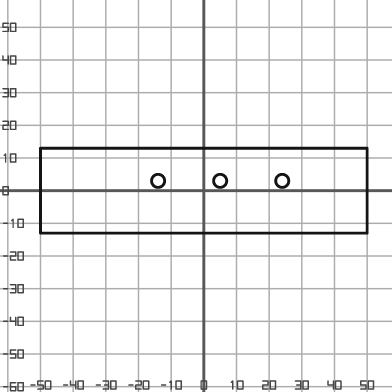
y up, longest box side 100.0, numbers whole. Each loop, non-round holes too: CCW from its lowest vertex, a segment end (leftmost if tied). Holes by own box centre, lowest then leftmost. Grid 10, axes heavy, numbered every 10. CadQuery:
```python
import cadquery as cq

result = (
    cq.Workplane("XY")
    .moveTo(-50.0, -13.0)
    .lineTo(50.0, -13.0)
    .lineTo(50.0, 13.0)
    .lineTo(-50.0, 13.0)
    .close()
    .moveTo(-14.0, 3.0)
    .circle(2.0)
    .moveTo(5.0, 3.0)
    .circle(2.0)
    .moveTo(24.0, 3.0)
    .circle(2.0)
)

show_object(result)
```